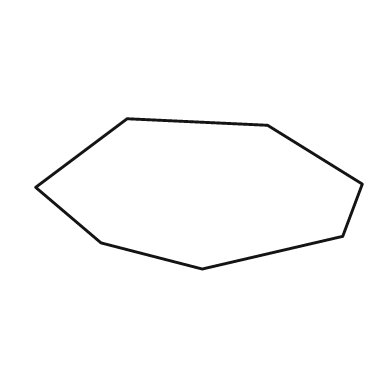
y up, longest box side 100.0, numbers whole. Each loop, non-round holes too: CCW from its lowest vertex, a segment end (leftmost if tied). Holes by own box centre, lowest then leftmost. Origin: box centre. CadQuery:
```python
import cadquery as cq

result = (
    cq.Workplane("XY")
    .moveTo(1.0, -23.0)
    .lineTo(44.0, -13.0)
    .lineTo(50.0, 3.0)
    .lineTo(21.0, 21.0)
    .lineTo(-22.0, 23.0)
    .lineTo(-50.0, 2.0)
    .lineTo(-30.0, -15.0)
    .close()
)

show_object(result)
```